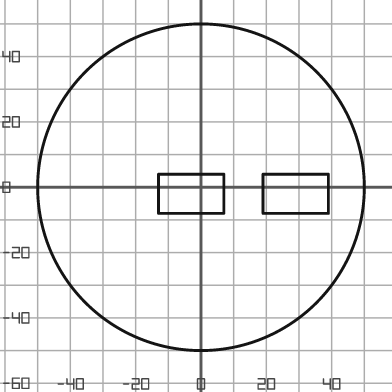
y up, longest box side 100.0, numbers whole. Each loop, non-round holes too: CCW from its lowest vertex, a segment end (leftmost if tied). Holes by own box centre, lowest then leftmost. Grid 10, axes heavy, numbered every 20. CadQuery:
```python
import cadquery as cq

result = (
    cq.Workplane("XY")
    .moveTo(0.0, 0.0)
    .circle(50.0)
    .moveTo(-13.0, -8.0)
    .lineTo(7.0, -8.0)
    .lineTo(7.0, 4.0)
    .lineTo(-13.0, 4.0)
    .close()
    .moveTo(19.0, -8.0)
    .lineTo(39.0, -8.0)
    .lineTo(39.0, 4.0)
    .lineTo(19.0, 4.0)
    .close()
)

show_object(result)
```